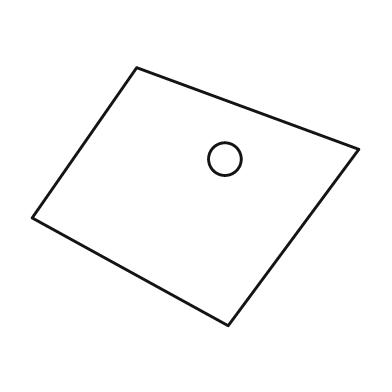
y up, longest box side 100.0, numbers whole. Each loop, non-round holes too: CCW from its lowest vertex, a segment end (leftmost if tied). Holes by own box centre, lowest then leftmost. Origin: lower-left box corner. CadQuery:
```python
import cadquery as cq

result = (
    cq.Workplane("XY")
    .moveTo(60.0, 0.0)
    .lineTo(100.0, 54.0)
    .lineTo(32.0, 79.0)
    .lineTo(0.0, 33.0)
    .close()
    .moveTo(59.0, 51.0)
    .circle(5.0)
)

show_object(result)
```